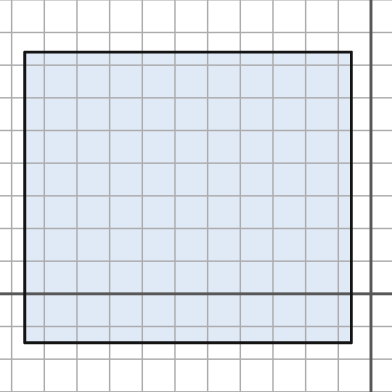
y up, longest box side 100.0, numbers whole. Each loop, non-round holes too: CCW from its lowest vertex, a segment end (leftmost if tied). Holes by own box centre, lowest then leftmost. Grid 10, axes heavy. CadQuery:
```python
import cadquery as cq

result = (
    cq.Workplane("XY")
    .moveTo(-106.0, -15.0)
    .lineTo(-6.0, -15.0)
    .lineTo(-6.0, 74.0)
    .lineTo(-106.0, 74.0)
    .close()
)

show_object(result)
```